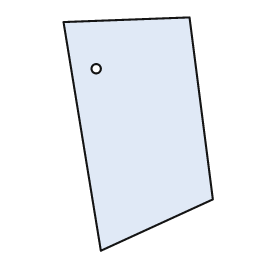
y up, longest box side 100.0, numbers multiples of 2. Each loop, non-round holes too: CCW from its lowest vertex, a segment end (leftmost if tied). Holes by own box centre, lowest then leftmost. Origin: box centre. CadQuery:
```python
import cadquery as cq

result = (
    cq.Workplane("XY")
    .moveTo(-16.0, -50.0)
    .lineTo(32.0, -28.0)
    .lineTo(22.0, 50.0)
    .lineTo(-32.0, 48.0)
    .close()
    .moveTo(-18.0, 28.0)
    .circle(2.0)
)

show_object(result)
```